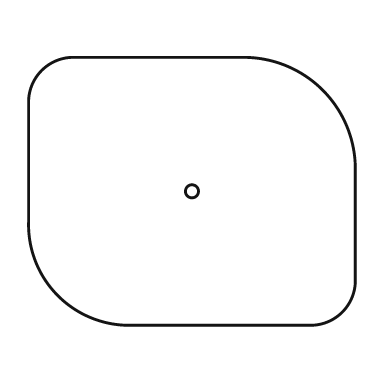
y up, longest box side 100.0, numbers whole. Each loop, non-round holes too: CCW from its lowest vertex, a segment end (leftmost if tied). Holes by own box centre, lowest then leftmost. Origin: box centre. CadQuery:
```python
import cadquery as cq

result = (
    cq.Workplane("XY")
    .moveTo(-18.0, -41.0)
    .lineTo(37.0, -41.0)
    .threePointArc((46.0, -37.0), (50.0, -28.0))
    .lineTo(50.0, 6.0)
    .threePointArc((40.0, 31.0), (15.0, 41.0))
    .lineTo(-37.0, 41.0)
    .threePointArc((-46.0, 37.0), (-50.0, 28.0))
    .lineTo(-50.0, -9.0)
    .threePointArc((-41.0, -32.0), (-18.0, -41.0))
    .close()
    .moveTo(0.0, 0.0)
    .circle(2.0)
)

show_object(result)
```